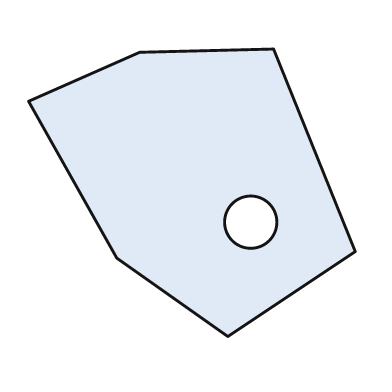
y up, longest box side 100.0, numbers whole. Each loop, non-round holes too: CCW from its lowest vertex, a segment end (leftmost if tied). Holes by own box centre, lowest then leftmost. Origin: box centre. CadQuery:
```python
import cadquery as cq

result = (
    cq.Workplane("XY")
    .moveTo(11.0, -44.0)
    .lineTo(50.0, -18.0)
    .lineTo(25.0, 44.0)
    .lineTo(-16.0, 43.0)
    .lineTo(-50.0, 28.0)
    .lineTo(-23.0, -20.0)
    .close()
    .moveTo(18.0, -9.0)
    .circle(8.0)
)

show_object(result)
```